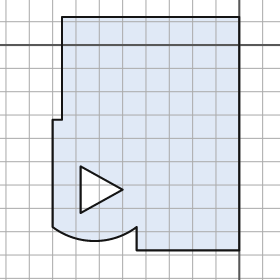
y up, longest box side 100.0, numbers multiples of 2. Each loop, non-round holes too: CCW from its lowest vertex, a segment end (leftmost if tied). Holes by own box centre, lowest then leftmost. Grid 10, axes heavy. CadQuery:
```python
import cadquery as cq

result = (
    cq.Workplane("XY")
    .moveTo(-44.0, -88.0)
    .lineTo(0.0, -88.0)
    .lineTo(0.0, 12.0)
    .lineTo(-76.0, 12.0)
    .lineTo(-76.0, -32.0)
    .lineTo(-80.0, -32.0)
    .lineTo(-80.0, -78.0)
    .threePointArc((-62.0, -84.0), (-44.0, -78.0))
    .close()
    .moveTo(-68.0, -72.0)
    .lineTo(-50.0, -62.0)
    .lineTo(-68.0, -52.0)
    .close()
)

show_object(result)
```